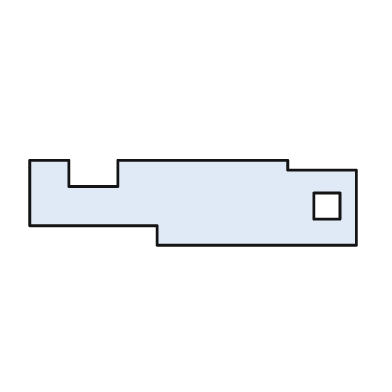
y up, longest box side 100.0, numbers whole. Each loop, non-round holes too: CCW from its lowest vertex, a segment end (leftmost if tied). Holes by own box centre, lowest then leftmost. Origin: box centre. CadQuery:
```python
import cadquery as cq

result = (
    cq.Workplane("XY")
    .moveTo(-11.0, -13.0)
    .lineTo(50.0, -13.0)
    .lineTo(50.0, 10.0)
    .lineTo(29.0, 10.0)
    .lineTo(29.0, 13.0)
    .lineTo(-23.0, 13.0)
    .lineTo(-23.0, 5.0)
    .lineTo(-38.0, 5.0)
    .lineTo(-38.0, 13.0)
    .lineTo(-50.0, 13.0)
    .lineTo(-50.0, -7.0)
    .lineTo(-11.0, -7.0)
    .close()
    .moveTo(37.0, -5.0)
    .lineTo(45.0, -5.0)
    .lineTo(45.0, 3.0)
    .lineTo(37.0, 3.0)
    .close()
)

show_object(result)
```